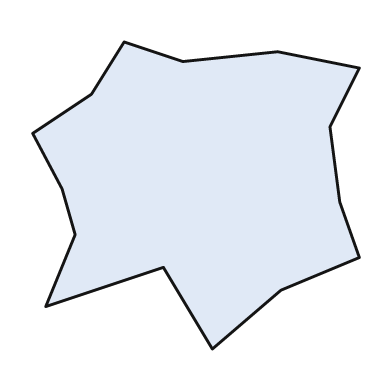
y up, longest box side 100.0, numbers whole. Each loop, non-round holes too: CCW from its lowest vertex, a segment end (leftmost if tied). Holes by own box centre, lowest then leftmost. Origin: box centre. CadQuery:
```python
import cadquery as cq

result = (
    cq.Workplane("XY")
    .moveTo(5.0, -47.0)
    .lineTo(26.0, -29.0)
    .lineTo(50.0, -19.0)
    .lineTo(44.0, -2.0)
    .lineTo(41.0, 21.0)
    .lineTo(50.0, 39.0)
    .lineTo(25.0, 44.0)
    .lineTo(-4.0, 41.0)
    .lineTo(-22.0, 47.0)
    .lineTo(-32.0, 31.0)
    .lineTo(-50.0, 19.0)
    .lineTo(-41.0, 2.0)
    .lineTo(-37.0, -12.0)
    .lineTo(-46.0, -34.0)
    .lineTo(-10.0, -22.0)
    .close()
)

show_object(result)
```